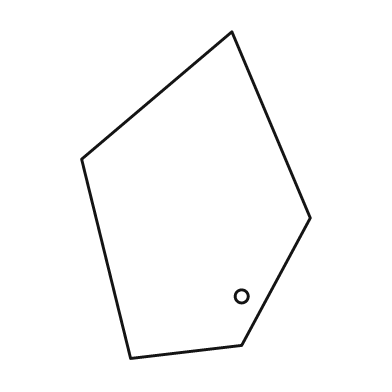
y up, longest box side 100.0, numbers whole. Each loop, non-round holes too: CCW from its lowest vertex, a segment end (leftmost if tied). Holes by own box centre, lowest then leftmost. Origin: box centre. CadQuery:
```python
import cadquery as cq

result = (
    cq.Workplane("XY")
    .moveTo(-20.0, -50.0)
    .lineTo(14.0, -46.0)
    .lineTo(35.0, -7.0)
    .lineTo(11.0, 50.0)
    .lineTo(-35.0, 11.0)
    .close()
    .moveTo(14.0, -31.0)
    .circle(2.0)
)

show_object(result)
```